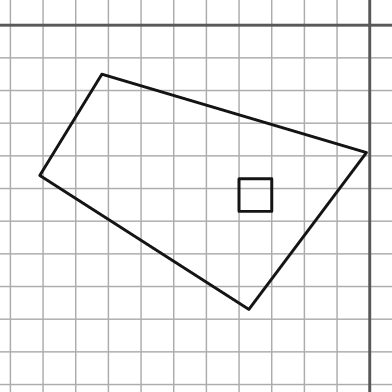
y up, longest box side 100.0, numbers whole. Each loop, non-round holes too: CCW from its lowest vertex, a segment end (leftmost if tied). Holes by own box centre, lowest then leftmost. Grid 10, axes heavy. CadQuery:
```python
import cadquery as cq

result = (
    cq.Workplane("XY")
    .moveTo(-37.0, -87.0)
    .lineTo(-1.0, -39.0)
    .lineTo(-82.0, -15.0)
    .lineTo(-101.0, -46.0)
    .close()
    .moveTo(-40.0, -57.0)
    .lineTo(-30.0, -57.0)
    .lineTo(-30.0, -47.0)
    .lineTo(-40.0, -47.0)
    .close()
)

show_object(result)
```